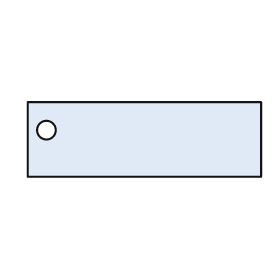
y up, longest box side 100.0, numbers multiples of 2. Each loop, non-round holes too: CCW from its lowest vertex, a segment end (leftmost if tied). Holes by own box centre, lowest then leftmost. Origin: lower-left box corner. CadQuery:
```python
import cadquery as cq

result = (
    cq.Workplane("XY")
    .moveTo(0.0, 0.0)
    .lineTo(100.0, 0.0)
    .lineTo(100.0, 32.0)
    .lineTo(0.0, 32.0)
    .close()
    .moveTo(8.0, 20.0)
    .circle(4.0)
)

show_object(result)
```